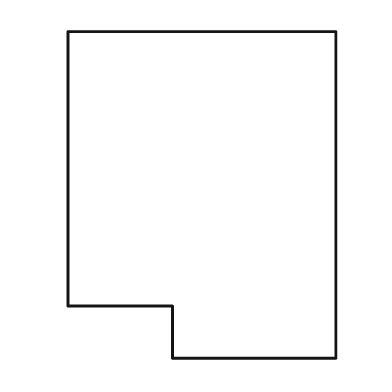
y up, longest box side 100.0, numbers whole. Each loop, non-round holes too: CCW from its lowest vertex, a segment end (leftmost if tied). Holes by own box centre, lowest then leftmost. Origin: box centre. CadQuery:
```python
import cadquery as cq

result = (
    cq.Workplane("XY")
    .moveTo(-9.0, -50.0)
    .lineTo(41.0, -50.0)
    .lineTo(41.0, 50.0)
    .lineTo(-41.0, 50.0)
    .lineTo(-41.0, -34.0)
    .lineTo(-9.0, -34.0)
    .close()
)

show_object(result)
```